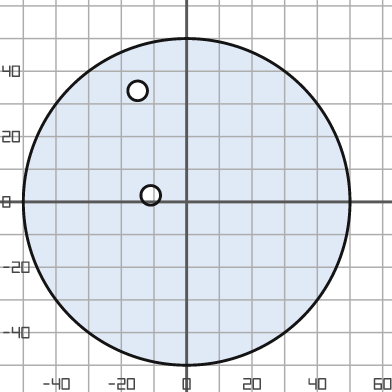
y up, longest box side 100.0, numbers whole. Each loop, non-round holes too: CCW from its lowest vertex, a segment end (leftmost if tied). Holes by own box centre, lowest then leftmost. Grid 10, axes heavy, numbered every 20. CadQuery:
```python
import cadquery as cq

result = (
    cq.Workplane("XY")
    .moveTo(0.0, 0.0)
    .circle(50.0)
    .moveTo(-11.0, 2.0)
    .circle(3.0)
    .moveTo(-15.0, 34.0)
    .circle(3.0)
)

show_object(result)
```